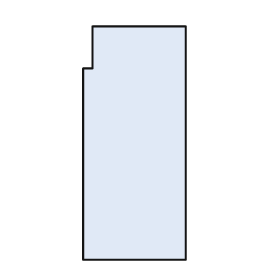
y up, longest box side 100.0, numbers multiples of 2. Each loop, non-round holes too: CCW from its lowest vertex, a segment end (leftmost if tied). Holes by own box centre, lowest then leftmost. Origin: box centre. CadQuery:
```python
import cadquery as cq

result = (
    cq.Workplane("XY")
    .moveTo(-22.0, -50.0)
    .lineTo(22.0, -50.0)
    .lineTo(22.0, 50.0)
    .lineTo(-18.0, 50.0)
    .lineTo(-18.0, 32.0)
    .lineTo(-22.0, 32.0)
    .close()
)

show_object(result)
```